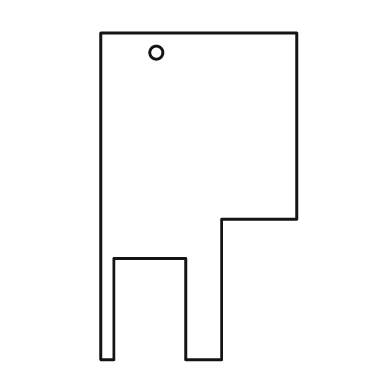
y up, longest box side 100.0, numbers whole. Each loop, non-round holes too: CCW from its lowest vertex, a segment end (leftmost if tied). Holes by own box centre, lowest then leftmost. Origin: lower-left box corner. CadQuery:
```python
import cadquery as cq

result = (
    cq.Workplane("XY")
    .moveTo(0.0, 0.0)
    .lineTo(4.0, 0.0)
    .lineTo(4.0, 31.0)
    .lineTo(26.0, 31.0)
    .lineTo(26.0, 0.0)
    .lineTo(37.0, 0.0)
    .lineTo(37.0, 43.0)
    .lineTo(60.0, 43.0)
    .lineTo(60.0, 100.0)
    .lineTo(0.0, 100.0)
    .close()
    .moveTo(17.0, 94.0)
    .circle(2.0)
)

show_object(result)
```